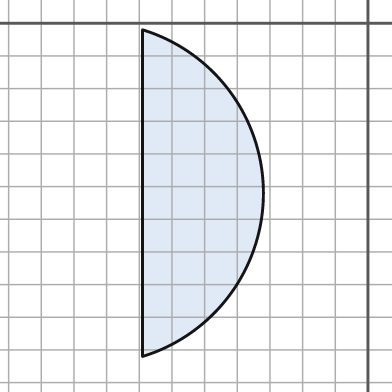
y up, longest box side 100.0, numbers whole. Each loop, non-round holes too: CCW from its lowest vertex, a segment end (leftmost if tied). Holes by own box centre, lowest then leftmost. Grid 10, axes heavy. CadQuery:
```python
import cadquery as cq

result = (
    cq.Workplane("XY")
    .moveTo(-69.0, -102.0)
    .threePointArc((-32.0, -52.0), (-69.0, -2.0))
    .close()
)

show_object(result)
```